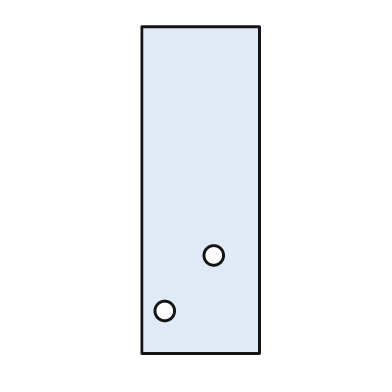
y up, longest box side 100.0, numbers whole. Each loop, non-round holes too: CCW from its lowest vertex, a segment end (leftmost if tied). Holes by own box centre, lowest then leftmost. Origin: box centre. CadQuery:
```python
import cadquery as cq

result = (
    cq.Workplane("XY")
    .moveTo(-18.0, -50.0)
    .lineTo(18.0, -50.0)
    .lineTo(18.0, 50.0)
    .lineTo(-18.0, 50.0)
    .close()
    .moveTo(-11.0, -37.0)
    .circle(3.0)
    .moveTo(4.0, -20.0)
    .circle(3.0)
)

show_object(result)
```